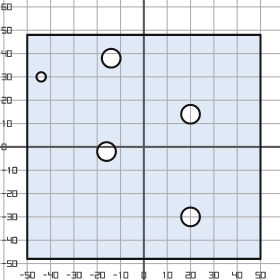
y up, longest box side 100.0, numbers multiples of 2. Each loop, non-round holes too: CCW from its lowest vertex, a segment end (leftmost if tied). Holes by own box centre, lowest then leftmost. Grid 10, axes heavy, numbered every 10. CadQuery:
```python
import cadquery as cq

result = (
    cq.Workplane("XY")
    .moveTo(-50.0, -48.0)
    .lineTo(50.0, -48.0)
    .lineTo(50.0, 48.0)
    .lineTo(-50.0, 48.0)
    .close()
    .moveTo(20.0, -30.0)
    .circle(4.0)
    .moveTo(-16.0, -2.0)
    .circle(4.0)
    .moveTo(20.0, 14.0)
    .circle(4.0)
    .moveTo(-44.0, 30.0)
    .circle(2.0)
    .moveTo(-14.0, 38.0)
    .circle(4.0)
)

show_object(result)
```